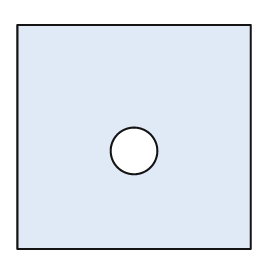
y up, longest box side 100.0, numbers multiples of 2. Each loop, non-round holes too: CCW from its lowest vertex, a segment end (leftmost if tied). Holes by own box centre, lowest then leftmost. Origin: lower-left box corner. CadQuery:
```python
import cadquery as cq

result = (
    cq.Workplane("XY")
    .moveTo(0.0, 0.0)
    .lineTo(100.0, 0.0)
    .lineTo(100.0, 96.0)
    .lineTo(0.0, 96.0)
    .close()
    .moveTo(50.0, 42.0)
    .circle(10.0)
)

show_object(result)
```